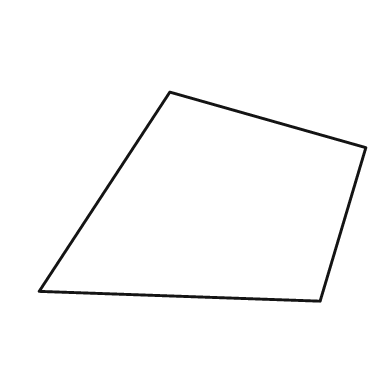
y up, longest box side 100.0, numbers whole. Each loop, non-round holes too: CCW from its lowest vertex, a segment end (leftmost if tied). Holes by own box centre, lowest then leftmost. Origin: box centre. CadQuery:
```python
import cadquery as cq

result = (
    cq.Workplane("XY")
    .moveTo(36.0, -32.0)
    .lineTo(50.0, 15.0)
    .lineTo(-10.0, 32.0)
    .lineTo(-50.0, -29.0)
    .close()
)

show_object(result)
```